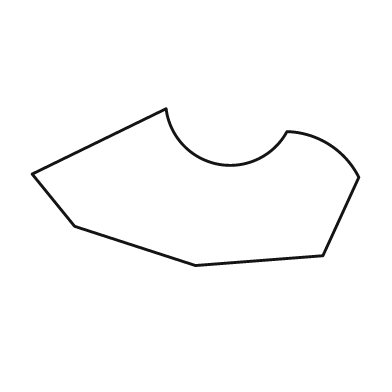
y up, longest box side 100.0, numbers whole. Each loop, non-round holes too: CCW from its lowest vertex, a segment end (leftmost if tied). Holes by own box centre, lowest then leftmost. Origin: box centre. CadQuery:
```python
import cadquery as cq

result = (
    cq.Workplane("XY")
    .moveTo(0.0, -24.0)
    .lineTo(39.0, -21.0)
    .lineTo(50.0, 3.0)
    .threePointArc((41.0, 13.0), (28.0, 17.0))
    .threePointArc((7.0, 7.0), (-9.0, 24.0))
    .lineTo(-50.0, 4.0)
    .lineTo(-37.0, -12.0)
    .close()
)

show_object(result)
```